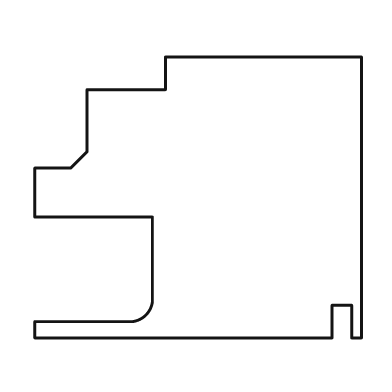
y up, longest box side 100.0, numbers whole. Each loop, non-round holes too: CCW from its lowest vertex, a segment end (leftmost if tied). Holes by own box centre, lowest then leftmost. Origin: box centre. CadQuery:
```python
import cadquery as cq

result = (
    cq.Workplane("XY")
    .moveTo(-50.0, -43.0)
    .lineTo(41.0, -43.0)
    .lineTo(41.0, -33.0)
    .lineTo(47.0, -33.0)
    .lineTo(47.0, -43.0)
    .lineTo(50.0, -43.0)
    .lineTo(50.0, 43.0)
    .lineTo(-10.0, 43.0)
    .lineTo(-10.0, 33.0)
    .lineTo(-34.0, 33.0)
    .lineTo(-34.0, 14.0)
    .lineTo(-39.0, 9.0)
    .lineTo(-50.0, 9.0)
    .lineTo(-50.0, -6.0)
    .lineTo(-14.0, -6.0)
    .lineTo(-14.0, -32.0)
    .threePointArc((-16.0, -36.0), (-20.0, -38.0))
    .lineTo(-50.0, -38.0)
    .close()
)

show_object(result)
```